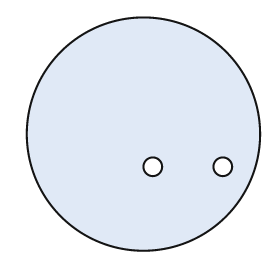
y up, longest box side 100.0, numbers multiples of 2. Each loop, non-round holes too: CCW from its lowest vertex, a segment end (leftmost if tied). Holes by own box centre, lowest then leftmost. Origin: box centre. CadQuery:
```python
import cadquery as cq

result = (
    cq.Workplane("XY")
    .moveTo(0.0, 0.0)
    .circle(50.0)
    .moveTo(4.0, -14.0)
    .circle(4.0)
    .moveTo(34.0, -14.0)
    .circle(4.0)
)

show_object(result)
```